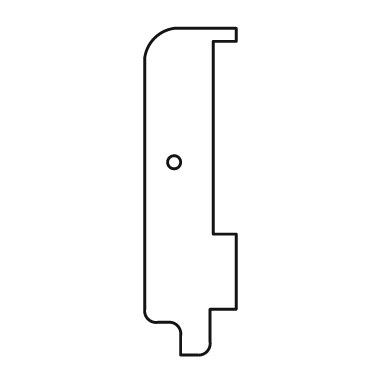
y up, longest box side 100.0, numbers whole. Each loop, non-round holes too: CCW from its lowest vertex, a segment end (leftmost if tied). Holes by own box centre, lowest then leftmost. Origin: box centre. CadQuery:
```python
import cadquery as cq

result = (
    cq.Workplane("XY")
    .moveTo(-3.0, -50.0)
    .lineTo(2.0, -50.0)
    .threePointArc((5.0, -49.0), (6.0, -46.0))
    .lineTo(6.0, -36.0)
    .lineTo(14.0, -36.0)
    .lineTo(14.0, -13.0)
    .lineTo(7.0, -13.0)
    .lineTo(7.0, 46.0)
    .lineTo(14.0, 46.0)
    .lineTo(14.0, 50.0)
    .lineTo(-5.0, 50.0)
    .threePointArc((-11.0, 47.0), (-14.0, 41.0))
    .lineTo(-14.0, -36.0)
    .threePointArc((-13.0, -39.0), (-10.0, -40.0))
    .lineTo(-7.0, -40.0)
    .threePointArc((-4.0, -41.0), (-3.0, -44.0))
    .close()
    .moveTo(-5.0, 9.0)
    .circle(2.0)
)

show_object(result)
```